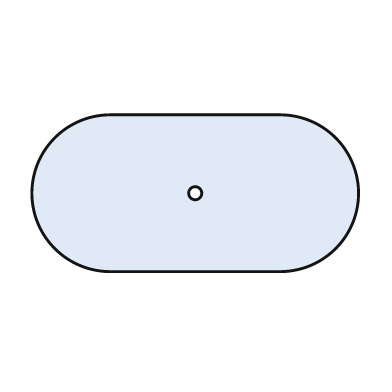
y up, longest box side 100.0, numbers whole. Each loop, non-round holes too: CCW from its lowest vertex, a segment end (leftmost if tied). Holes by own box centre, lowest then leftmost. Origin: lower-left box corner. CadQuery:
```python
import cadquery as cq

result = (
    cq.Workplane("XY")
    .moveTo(24.0, 0.0)
    .lineTo(76.0, 0.0)
    .threePointArc((100.0, 24.0), (76.0, 48.0))
    .lineTo(24.0, 48.0)
    .threePointArc((0.0, 24.0), (24.0, 0.0))
    .close()
    .moveTo(50.0, 24.0)
    .circle(2.0)
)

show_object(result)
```